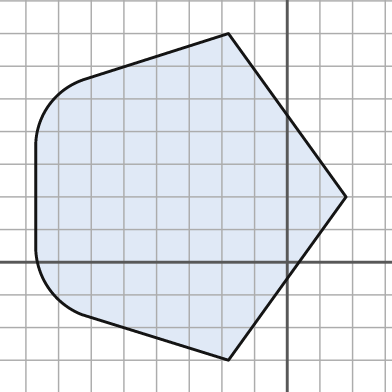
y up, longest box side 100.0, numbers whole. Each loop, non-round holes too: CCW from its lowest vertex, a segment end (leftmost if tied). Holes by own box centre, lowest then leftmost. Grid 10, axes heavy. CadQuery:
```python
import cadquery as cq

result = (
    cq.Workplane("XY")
    .moveTo(-18.0, -30.0)
    .lineTo(18.0, 20.0)
    .lineTo(-18.0, 70.0)
    .lineTo(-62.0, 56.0)
    .threePointArc((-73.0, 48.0), (-77.0, 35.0))
    .lineTo(-77.0, 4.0)
    .threePointArc((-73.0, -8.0), (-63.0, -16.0))
    .close()
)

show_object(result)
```